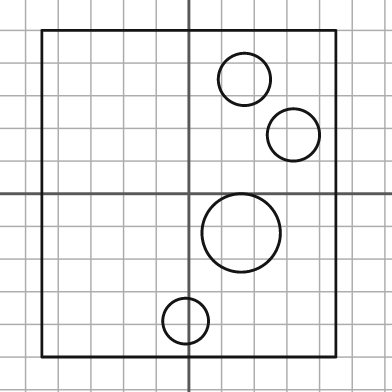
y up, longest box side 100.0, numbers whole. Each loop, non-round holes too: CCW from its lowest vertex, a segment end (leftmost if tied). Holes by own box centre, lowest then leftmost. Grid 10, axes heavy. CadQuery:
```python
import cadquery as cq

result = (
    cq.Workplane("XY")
    .moveTo(-45.0, -50.0)
    .lineTo(45.0, -50.0)
    .lineTo(45.0, 50.0)
    .lineTo(-45.0, 50.0)
    .close()
    .moveTo(-1.0, -39.0)
    .circle(7.0)
    .moveTo(16.0, -12.0)
    .circle(12.0)
    .moveTo(32.0, 18.0)
    .circle(8.0)
    .moveTo(17.0, 35.0)
    .circle(8.0)
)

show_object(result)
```